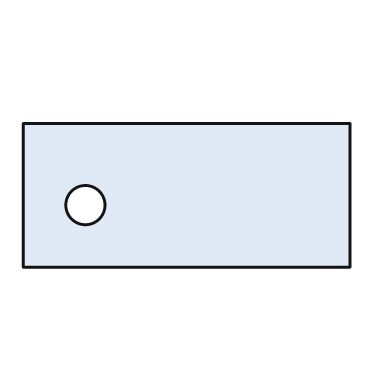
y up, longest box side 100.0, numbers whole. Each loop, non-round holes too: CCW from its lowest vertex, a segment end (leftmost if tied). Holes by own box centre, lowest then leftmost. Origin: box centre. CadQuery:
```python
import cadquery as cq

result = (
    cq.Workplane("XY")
    .moveTo(-50.0, -22.0)
    .lineTo(50.0, -22.0)
    .lineTo(50.0, 22.0)
    .lineTo(-50.0, 22.0)
    .close()
    .moveTo(-31.0, -3.0)
    .circle(6.0)
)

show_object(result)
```